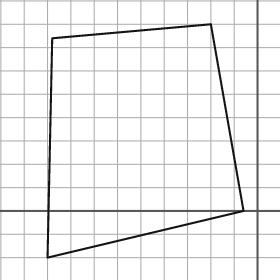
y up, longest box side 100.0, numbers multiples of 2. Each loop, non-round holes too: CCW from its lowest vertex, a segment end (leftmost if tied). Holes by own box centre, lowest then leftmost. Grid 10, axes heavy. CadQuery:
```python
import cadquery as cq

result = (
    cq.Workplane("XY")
    .moveTo(-90.0, -20.0)
    .lineTo(-6.0, 0.0)
    .lineTo(-20.0, 80.0)
    .lineTo(-88.0, 74.0)
    .close()
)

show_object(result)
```